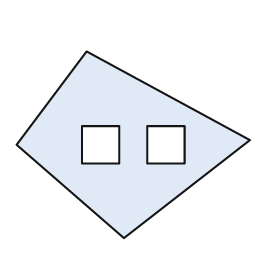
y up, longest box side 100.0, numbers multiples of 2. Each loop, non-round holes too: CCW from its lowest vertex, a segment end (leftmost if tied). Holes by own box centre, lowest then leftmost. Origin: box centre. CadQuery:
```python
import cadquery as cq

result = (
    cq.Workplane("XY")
    .moveTo(-4.0, -40.0)
    .lineTo(50.0, 2.0)
    .lineTo(-20.0, 40.0)
    .lineTo(-50.0, 0.0)
    .close()
    .moveTo(-22.0, -8.0)
    .lineTo(-6.0, -8.0)
    .lineTo(-6.0, 8.0)
    .lineTo(-22.0, 8.0)
    .close()
    .moveTo(6.0, -8.0)
    .lineTo(22.0, -8.0)
    .lineTo(22.0, 8.0)
    .lineTo(6.0, 8.0)
    .close()
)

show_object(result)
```